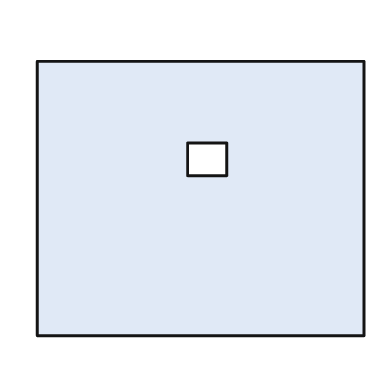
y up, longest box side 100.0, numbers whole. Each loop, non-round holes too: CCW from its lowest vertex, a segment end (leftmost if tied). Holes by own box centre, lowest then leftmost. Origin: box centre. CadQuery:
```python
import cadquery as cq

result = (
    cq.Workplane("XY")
    .moveTo(-50.0, -42.0)
    .lineTo(50.0, -42.0)
    .lineTo(50.0, 42.0)
    .lineTo(-50.0, 42.0)
    .close()
    .moveTo(-4.0, 7.0)
    .lineTo(8.0, 7.0)
    .lineTo(8.0, 17.0)
    .lineTo(-4.0, 17.0)
    .close()
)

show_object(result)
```